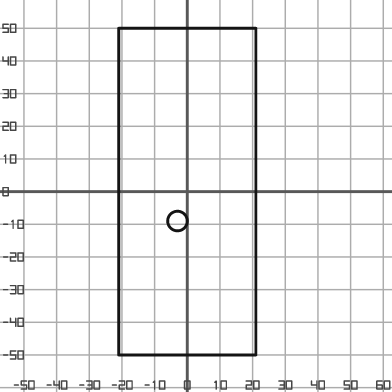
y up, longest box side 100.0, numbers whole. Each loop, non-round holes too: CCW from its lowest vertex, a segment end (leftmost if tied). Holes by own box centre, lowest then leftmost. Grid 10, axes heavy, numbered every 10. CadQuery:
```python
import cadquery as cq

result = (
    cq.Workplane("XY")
    .moveTo(-21.0, -50.0)
    .lineTo(21.0, -50.0)
    .lineTo(21.0, 50.0)
    .lineTo(-21.0, 50.0)
    .close()
    .moveTo(-3.0, -9.0)
    .circle(3.0)
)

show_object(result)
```